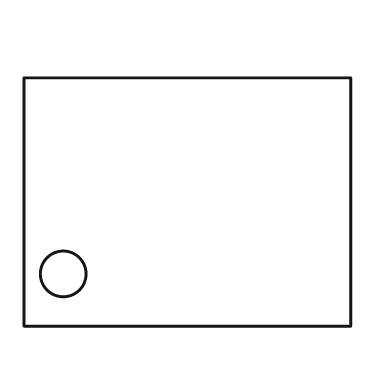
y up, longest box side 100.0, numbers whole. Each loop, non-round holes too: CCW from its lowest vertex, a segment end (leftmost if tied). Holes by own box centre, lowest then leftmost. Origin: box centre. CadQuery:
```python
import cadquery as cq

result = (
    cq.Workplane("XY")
    .moveTo(-50.0, -38.0)
    .lineTo(50.0, -38.0)
    .lineTo(50.0, 38.0)
    .lineTo(-50.0, 38.0)
    .close()
    .moveTo(-38.0, -22.0)
    .circle(7.0)
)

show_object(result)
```